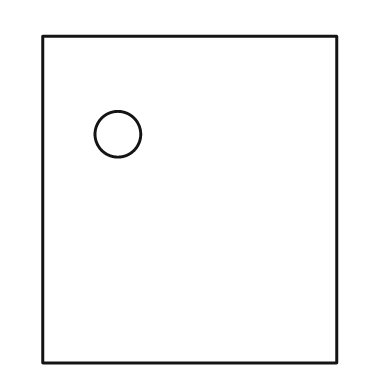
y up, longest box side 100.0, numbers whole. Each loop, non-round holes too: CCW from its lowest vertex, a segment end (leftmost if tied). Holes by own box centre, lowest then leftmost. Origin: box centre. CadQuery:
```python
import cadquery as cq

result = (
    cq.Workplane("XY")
    .moveTo(-45.0, -50.0)
    .lineTo(45.0, -50.0)
    .lineTo(45.0, 50.0)
    .lineTo(-45.0, 50.0)
    .close()
    .moveTo(-22.0, 20.0)
    .circle(7.0)
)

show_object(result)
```